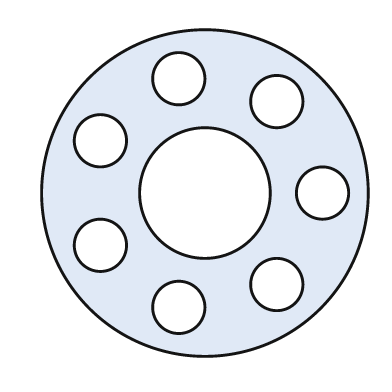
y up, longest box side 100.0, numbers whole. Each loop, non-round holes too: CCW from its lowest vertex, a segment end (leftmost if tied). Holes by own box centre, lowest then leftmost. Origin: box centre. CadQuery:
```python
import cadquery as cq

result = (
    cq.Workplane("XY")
    .moveTo(0.0, 0.0)
    .circle(50.0)
    .moveTo(-8.0, -35.0)
    .circle(8.0)
    .moveTo(22.0, -28.0)
    .circle(8.0)
    .moveTo(-32.0, -16.0)
    .circle(8.0)
    .moveTo(0.0, 0.0)
    .circle(20.0)
    .moveTo(36.0, 0.0)
    .circle(8.0)
    .moveTo(-32.0, 16.0)
    .circle(8.0)
    .moveTo(22.0, 28.0)
    .circle(8.0)
    .moveTo(-8.0, 35.0)
    .circle(8.0)
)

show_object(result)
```